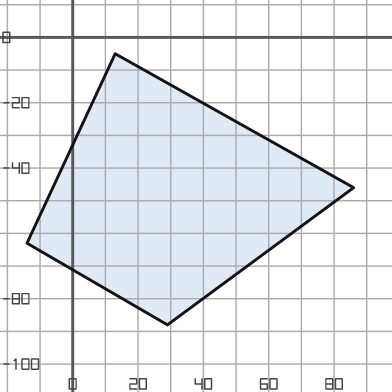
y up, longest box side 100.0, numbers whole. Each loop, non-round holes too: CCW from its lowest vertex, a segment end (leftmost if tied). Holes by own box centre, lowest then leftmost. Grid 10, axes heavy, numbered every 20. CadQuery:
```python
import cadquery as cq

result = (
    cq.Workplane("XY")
    .moveTo(29.0, -88.0)
    .lineTo(86.0, -46.0)
    .lineTo(13.0, -5.0)
    .lineTo(-14.0, -63.0)
    .close()
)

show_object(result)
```